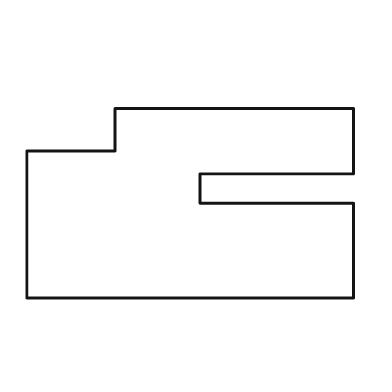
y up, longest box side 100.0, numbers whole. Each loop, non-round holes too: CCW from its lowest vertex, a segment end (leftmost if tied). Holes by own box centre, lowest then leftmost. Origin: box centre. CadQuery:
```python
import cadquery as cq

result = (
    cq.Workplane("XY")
    .moveTo(-50.0, -29.0)
    .lineTo(50.0, -29.0)
    .lineTo(50.0, 0.0)
    .lineTo(3.0, 0.0)
    .lineTo(3.0, 9.0)
    .lineTo(50.0, 9.0)
    .lineTo(50.0, 29.0)
    .lineTo(-23.0, 29.0)
    .lineTo(-23.0, 16.0)
    .lineTo(-50.0, 16.0)
    .close()
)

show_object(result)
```